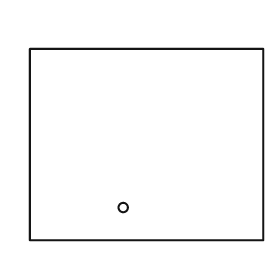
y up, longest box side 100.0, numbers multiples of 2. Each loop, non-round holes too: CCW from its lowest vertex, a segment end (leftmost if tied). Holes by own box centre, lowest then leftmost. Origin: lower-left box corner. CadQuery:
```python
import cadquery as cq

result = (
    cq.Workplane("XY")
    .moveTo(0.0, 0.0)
    .lineTo(100.0, 0.0)
    .lineTo(100.0, 82.0)
    .lineTo(0.0, 82.0)
    .close()
    .moveTo(40.0, 14.0)
    .circle(2.0)
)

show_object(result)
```